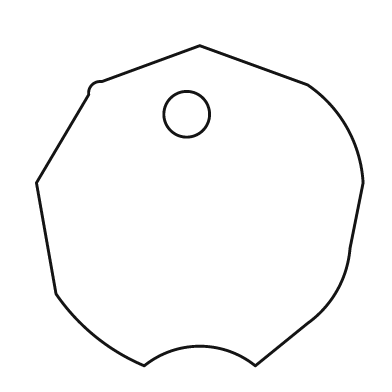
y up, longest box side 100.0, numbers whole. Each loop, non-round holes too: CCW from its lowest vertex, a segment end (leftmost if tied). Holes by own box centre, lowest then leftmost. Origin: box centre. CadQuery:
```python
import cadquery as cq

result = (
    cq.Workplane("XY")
    .moveTo(-17.0, -49.0)
    .threePointArc((0.0, -43.0), (17.0, -49.0))
    .lineTo(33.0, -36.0)
    .threePointArc((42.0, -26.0), (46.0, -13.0))
    .lineTo(50.0, 7.0)
    .threePointArc((45.0, 24.0), (33.0, 37.0))
    .lineTo(0.0, 49.0)
    .lineTo(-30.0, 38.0)
    .threePointArc((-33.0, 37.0), (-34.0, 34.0))
    .lineTo(-50.0, 7.0)
    .lineTo(-44.0, -27.0)
    .threePointArc((-32.0, -40.0), (-17.0, -49.0))
    .close()
    .moveTo(-4.0, 28.0)
    .circle(7.0)
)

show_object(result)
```